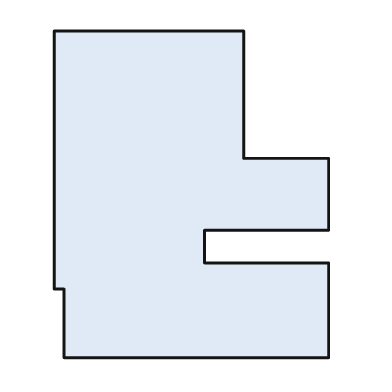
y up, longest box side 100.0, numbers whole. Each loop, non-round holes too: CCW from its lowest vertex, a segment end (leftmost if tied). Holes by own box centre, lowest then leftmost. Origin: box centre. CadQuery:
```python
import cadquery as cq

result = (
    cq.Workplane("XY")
    .moveTo(-39.0, -50.0)
    .lineTo(42.0, -50.0)
    .lineTo(42.0, -21.0)
    .lineTo(4.0, -21.0)
    .lineTo(4.0, -11.0)
    .lineTo(42.0, -11.0)
    .lineTo(42.0, 11.0)
    .lineTo(16.0, 11.0)
    .lineTo(16.0, 50.0)
    .lineTo(-42.0, 50.0)
    .lineTo(-42.0, -29.0)
    .lineTo(-39.0, -29.0)
    .close()
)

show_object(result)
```